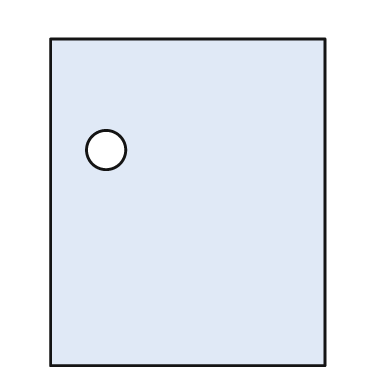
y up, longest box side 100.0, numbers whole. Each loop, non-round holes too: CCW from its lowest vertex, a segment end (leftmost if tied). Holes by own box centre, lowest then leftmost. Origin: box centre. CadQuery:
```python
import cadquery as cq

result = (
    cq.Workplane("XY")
    .moveTo(-42.0, -50.0)
    .lineTo(42.0, -50.0)
    .lineTo(42.0, 50.0)
    .lineTo(-42.0, 50.0)
    .close()
    .moveTo(-25.0, 16.0)
    .circle(6.0)
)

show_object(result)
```